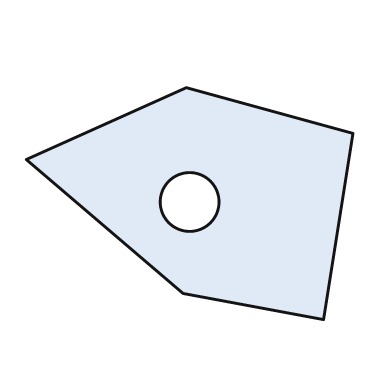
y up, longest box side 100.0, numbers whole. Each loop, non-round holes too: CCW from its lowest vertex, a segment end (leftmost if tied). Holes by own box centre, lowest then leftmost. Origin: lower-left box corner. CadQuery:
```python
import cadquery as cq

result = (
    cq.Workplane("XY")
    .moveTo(91.0, 0.0)
    .lineTo(100.0, 57.0)
    .lineTo(49.0, 71.0)
    .lineTo(0.0, 49.0)
    .lineTo(48.0, 8.0)
    .close()
    .moveTo(50.0, 36.0)
    .circle(9.0)
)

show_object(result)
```